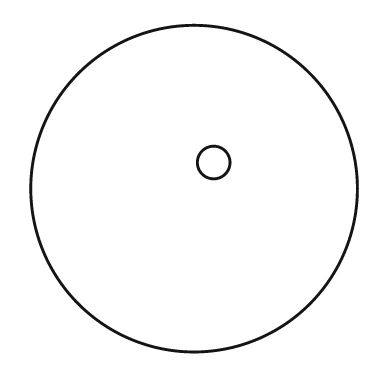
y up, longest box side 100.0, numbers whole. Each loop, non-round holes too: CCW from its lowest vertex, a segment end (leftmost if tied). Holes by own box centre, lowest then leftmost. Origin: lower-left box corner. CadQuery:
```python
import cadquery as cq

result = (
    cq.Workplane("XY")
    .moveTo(50.0, 50.0)
    .circle(50.0)
    .moveTo(56.0, 58.0)
    .circle(5.0)
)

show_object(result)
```